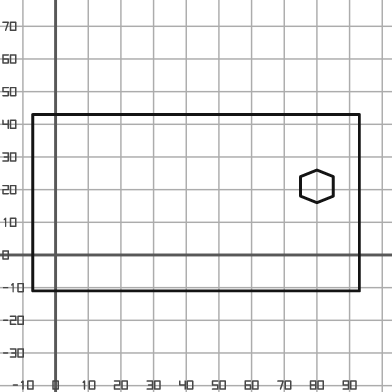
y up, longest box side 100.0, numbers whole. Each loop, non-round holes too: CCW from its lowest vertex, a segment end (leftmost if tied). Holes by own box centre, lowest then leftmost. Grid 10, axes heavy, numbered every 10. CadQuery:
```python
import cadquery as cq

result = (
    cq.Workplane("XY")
    .moveTo(-7.0, -11.0)
    .lineTo(93.0, -11.0)
    .lineTo(93.0, 43.0)
    .lineTo(-7.0, 43.0)
    .close()
    .moveTo(80.0, 16.0)
    .lineTo(85.0, 18.0)
    .lineTo(85.0, 24.0)
    .lineTo(80.0, 26.0)
    .lineTo(75.0, 24.0)
    .lineTo(75.0, 18.0)
    .close()
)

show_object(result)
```